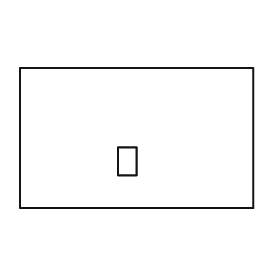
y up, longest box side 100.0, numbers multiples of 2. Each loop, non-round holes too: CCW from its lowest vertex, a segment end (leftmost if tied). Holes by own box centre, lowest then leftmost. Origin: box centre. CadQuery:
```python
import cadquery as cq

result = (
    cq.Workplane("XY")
    .moveTo(-50.0, -30.0)
    .lineTo(50.0, -30.0)
    .lineTo(50.0, 30.0)
    .lineTo(-50.0, 30.0)
    .close()
    .moveTo(-8.0, -16.0)
    .lineTo(0.0, -16.0)
    .lineTo(0.0, -4.0)
    .lineTo(-8.0, -4.0)
    .close()
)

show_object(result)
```